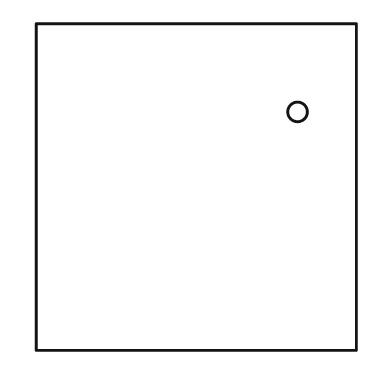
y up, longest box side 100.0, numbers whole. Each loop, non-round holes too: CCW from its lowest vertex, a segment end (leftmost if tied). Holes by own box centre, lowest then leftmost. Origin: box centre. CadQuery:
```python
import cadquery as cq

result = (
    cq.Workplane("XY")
    .moveTo(-49.0, -50.0)
    .lineTo(49.0, -50.0)
    .lineTo(49.0, 50.0)
    .lineTo(-49.0, 50.0)
    .close()
    .moveTo(31.0, 23.0)
    .circle(3.0)
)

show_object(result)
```